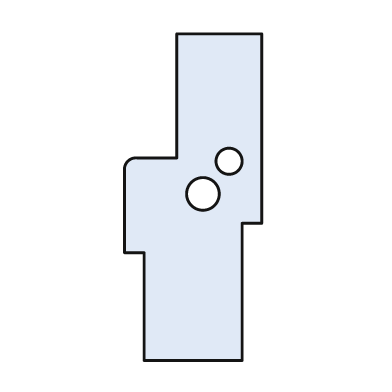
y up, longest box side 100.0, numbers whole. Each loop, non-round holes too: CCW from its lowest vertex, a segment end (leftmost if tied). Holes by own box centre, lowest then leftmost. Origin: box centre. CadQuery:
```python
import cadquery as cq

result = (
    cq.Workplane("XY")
    .moveTo(-15.0, -50.0)
    .lineTo(15.0, -50.0)
    .lineTo(15.0, -8.0)
    .lineTo(21.0, -8.0)
    .lineTo(21.0, 50.0)
    .lineTo(-5.0, 50.0)
    .lineTo(-5.0, 12.0)
    .lineTo(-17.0, 12.0)
    .threePointArc((-20.0, 11.0), (-21.0, 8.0))
    .lineTo(-21.0, -17.0)
    .lineTo(-15.0, -17.0)
    .close()
    .moveTo(3.0, 1.0)
    .circle(5.0)
    .moveTo(11.0, 11.0)
    .circle(4.0)
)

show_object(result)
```